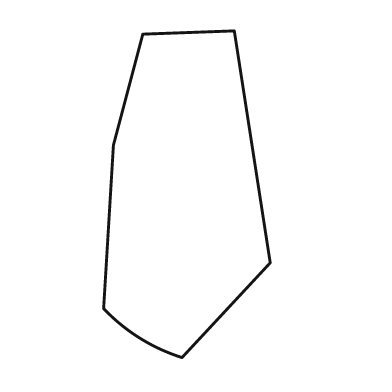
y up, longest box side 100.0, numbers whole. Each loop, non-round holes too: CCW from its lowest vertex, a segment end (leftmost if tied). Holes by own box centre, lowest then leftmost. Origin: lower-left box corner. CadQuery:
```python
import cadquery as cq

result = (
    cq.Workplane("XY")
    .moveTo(24.0, 0.0)
    .lineTo(51.0, 29.0)
    .lineTo(40.0, 100.0)
    .lineTo(12.0, 99.0)
    .lineTo(3.0, 65.0)
    .lineTo(0.0, 15.0)
    .threePointArc((11.0, 6.0), (24.0, 0.0))
    .close()
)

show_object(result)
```